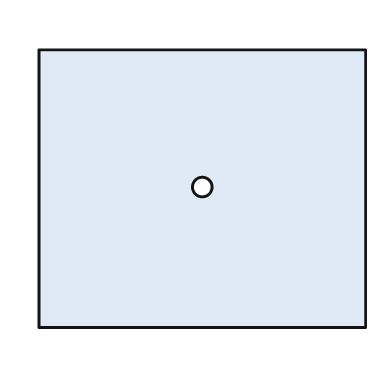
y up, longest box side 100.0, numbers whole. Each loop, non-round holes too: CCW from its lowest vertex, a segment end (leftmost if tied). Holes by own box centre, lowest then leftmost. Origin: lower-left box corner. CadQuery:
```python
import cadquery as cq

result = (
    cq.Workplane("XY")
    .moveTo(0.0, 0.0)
    .lineTo(100.0, 0.0)
    .lineTo(100.0, 85.0)
    .lineTo(0.0, 85.0)
    .close()
    .moveTo(50.0, 43.0)
    .circle(3.0)
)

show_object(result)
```